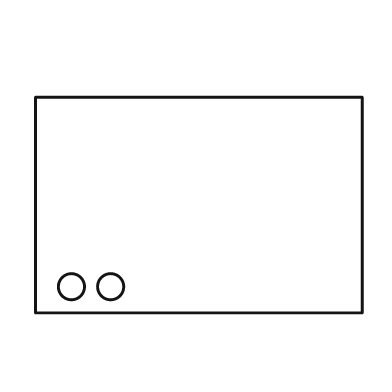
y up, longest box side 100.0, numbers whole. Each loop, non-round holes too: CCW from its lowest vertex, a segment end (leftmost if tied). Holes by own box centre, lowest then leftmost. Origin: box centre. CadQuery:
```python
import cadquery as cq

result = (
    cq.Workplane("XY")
    .moveTo(-50.0, -33.0)
    .lineTo(50.0, -33.0)
    .lineTo(50.0, 33.0)
    .lineTo(-50.0, 33.0)
    .close()
    .moveTo(-39.0, -25.0)
    .circle(4.0)
    .moveTo(-27.0, -25.0)
    .circle(4.0)
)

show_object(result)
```